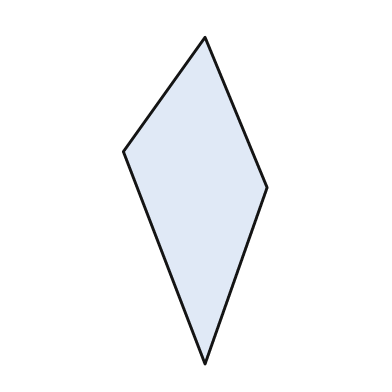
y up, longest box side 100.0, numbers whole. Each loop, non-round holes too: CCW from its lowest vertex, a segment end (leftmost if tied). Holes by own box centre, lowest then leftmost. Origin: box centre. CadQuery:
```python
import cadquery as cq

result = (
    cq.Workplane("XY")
    .moveTo(3.0, -50.0)
    .lineTo(22.0, 4.0)
    .lineTo(3.0, 50.0)
    .lineTo(-22.0, 15.0)
    .close()
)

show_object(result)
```